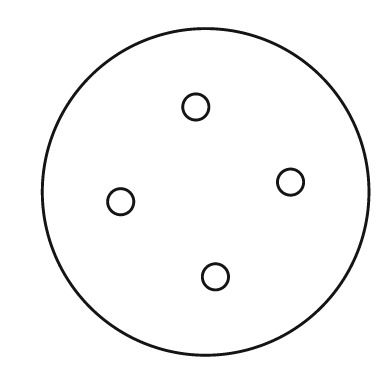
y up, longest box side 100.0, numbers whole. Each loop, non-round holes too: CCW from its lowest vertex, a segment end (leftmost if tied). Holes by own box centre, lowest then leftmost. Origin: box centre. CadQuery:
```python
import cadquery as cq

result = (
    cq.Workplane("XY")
    .moveTo(0.0, 0.0)
    .circle(50.0)
    .moveTo(3.0, -26.0)
    .circle(4.0)
    .moveTo(-26.0, -3.0)
    .circle(4.0)
    .moveTo(26.0, 3.0)
    .circle(4.0)
    .moveTo(-3.0, 26.0)
    .circle(4.0)
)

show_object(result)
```